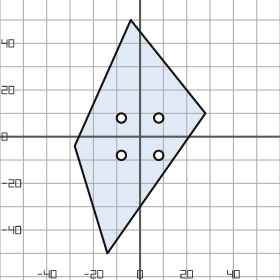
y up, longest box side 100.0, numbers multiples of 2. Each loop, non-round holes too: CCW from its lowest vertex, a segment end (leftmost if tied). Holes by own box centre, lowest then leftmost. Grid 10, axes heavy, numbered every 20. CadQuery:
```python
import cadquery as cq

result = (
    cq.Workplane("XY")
    .moveTo(-14.0, -50.0)
    .lineTo(28.0, 10.0)
    .lineTo(-4.0, 50.0)
    .lineTo(-28.0, -4.0)
    .close()
    .moveTo(-8.0, -8.0)
    .circle(2.0)
    .moveTo(8.0, -8.0)
    .circle(2.0)
    .moveTo(-8.0, 8.0)
    .circle(2.0)
    .moveTo(8.0, 8.0)
    .circle(2.0)
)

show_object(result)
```